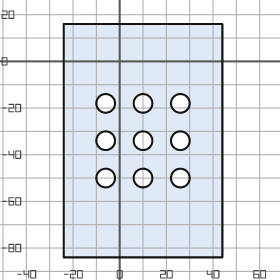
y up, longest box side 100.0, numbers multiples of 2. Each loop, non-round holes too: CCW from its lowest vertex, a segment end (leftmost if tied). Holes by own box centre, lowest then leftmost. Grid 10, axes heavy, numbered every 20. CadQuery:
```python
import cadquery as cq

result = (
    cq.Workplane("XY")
    .moveTo(-24.0, -84.0)
    .lineTo(44.0, -84.0)
    .lineTo(44.0, 16.0)
    .lineTo(-24.0, 16.0)
    .close()
    .moveTo(-6.0, -50.0)
    .circle(4.0)
    .moveTo(10.0, -50.0)
    .circle(4.0)
    .moveTo(26.0, -50.0)
    .circle(4.0)
    .moveTo(-6.0, -34.0)
    .circle(4.0)
    .moveTo(10.0, -34.0)
    .circle(4.0)
    .moveTo(26.0, -34.0)
    .circle(4.0)
    .moveTo(-6.0, -18.0)
    .circle(4.0)
    .moveTo(10.0, -18.0)
    .circle(4.0)
    .moveTo(26.0, -18.0)
    .circle(4.0)
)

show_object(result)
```